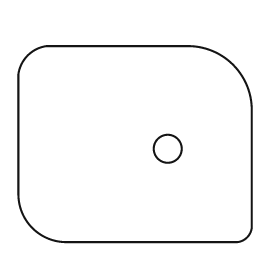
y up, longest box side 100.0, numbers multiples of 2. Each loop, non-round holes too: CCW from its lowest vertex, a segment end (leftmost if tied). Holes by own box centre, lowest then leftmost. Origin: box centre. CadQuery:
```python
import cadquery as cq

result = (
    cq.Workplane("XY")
    .moveTo(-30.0, -42.0)
    .lineTo(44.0, -42.0)
    .threePointArc((48.0, -40.0), (50.0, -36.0))
    .lineTo(50.0, 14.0)
    .threePointArc((42.0, 34.0), (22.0, 42.0))
    .lineTo(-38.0, 42.0)
    .threePointArc((-46.0, 38.0), (-50.0, 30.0))
    .lineTo(-50.0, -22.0)
    .threePointArc((-44.0, -36.0), (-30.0, -42.0))
    .close()
    .moveTo(14.0, -2.0)
    .circle(6.0)
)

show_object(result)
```